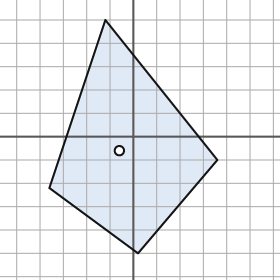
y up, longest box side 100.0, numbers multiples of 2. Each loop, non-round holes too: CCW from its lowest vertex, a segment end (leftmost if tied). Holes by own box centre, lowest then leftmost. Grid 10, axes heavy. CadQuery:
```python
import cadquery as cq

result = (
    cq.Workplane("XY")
    .moveTo(2.0, -50.0)
    .lineTo(36.0, -10.0)
    .lineTo(-12.0, 50.0)
    .lineTo(-36.0, -22.0)
    .close()
    .moveTo(-6.0, -6.0)
    .circle(2.0)
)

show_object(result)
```